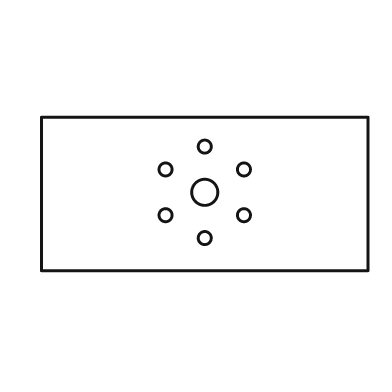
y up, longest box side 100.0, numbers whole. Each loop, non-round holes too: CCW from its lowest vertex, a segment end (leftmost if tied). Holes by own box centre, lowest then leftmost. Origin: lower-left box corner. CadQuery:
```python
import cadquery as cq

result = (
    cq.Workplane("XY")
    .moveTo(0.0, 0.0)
    .lineTo(100.0, 0.0)
    .lineTo(100.0, 47.0)
    .lineTo(0.0, 47.0)
    .close()
    .moveTo(50.0, 10.0)
    .circle(2.0)
    .moveTo(38.0, 17.0)
    .circle(2.0)
    .moveTo(62.0, 17.0)
    .circle(2.0)
    .moveTo(50.0, 24.0)
    .circle(4.0)
    .moveTo(38.0, 31.0)
    .circle(2.0)
    .moveTo(62.0, 31.0)
    .circle(2.0)
    .moveTo(50.0, 38.0)
    .circle(2.0)
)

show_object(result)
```